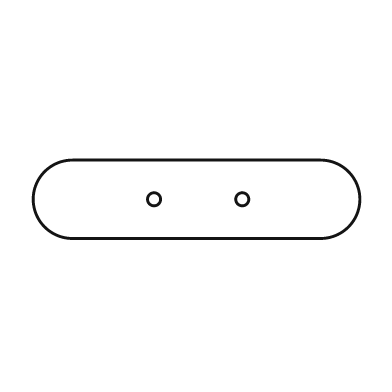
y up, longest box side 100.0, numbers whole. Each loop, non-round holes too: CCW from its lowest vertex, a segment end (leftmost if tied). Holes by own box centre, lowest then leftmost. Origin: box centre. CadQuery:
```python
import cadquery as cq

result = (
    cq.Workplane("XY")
    .moveTo(-38.0, -12.0)
    .lineTo(38.0, -12.0)
    .threePointArc((50.0, 0.0), (38.0, 12.0))
    .lineTo(-38.0, 12.0)
    .threePointArc((-50.0, 0.0), (-38.0, -12.0))
    .close()
    .moveTo(-13.0, 0.0)
    .circle(2.0)
    .moveTo(14.0, 0.0)
    .circle(2.0)
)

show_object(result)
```